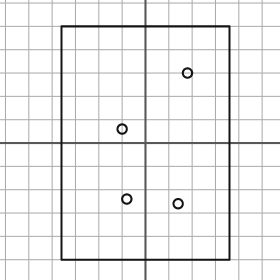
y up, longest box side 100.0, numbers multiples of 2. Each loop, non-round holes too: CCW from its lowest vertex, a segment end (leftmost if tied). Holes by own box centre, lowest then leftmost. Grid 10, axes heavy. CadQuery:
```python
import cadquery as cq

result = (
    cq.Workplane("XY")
    .moveTo(-36.0, -50.0)
    .lineTo(36.0, -50.0)
    .lineTo(36.0, 50.0)
    .lineTo(-36.0, 50.0)
    .close()
    .moveTo(14.0, -26.0)
    .circle(2.0)
    .moveTo(-8.0, -24.0)
    .circle(2.0)
    .moveTo(-10.0, 6.0)
    .circle(2.0)
    .moveTo(18.0, 30.0)
    .circle(2.0)
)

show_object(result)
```